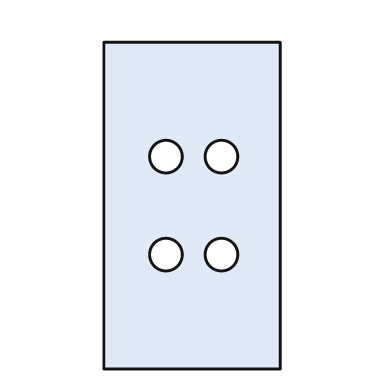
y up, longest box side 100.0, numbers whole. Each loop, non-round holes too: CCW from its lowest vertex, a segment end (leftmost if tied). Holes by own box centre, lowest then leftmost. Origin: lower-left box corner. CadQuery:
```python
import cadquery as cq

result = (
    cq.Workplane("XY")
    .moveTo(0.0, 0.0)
    .lineTo(54.0, 0.0)
    .lineTo(54.0, 100.0)
    .lineTo(0.0, 100.0)
    .close()
    .moveTo(19.0, 35.0)
    .circle(5.0)
    .moveTo(36.0, 35.0)
    .circle(5.0)
    .moveTo(19.0, 65.0)
    .circle(5.0)
    .moveTo(36.0, 65.0)
    .circle(5.0)
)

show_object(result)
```